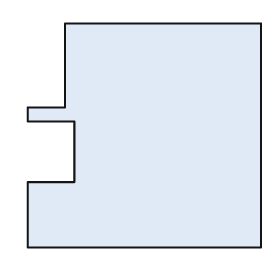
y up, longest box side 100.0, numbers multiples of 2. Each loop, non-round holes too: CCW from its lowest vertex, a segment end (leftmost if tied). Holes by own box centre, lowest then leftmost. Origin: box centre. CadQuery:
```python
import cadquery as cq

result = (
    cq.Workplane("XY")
    .moveTo(-50.0, -48.0)
    .lineTo(50.0, -48.0)
    .lineTo(50.0, 48.0)
    .lineTo(-34.0, 48.0)
    .lineTo(-34.0, 12.0)
    .lineTo(-50.0, 12.0)
    .lineTo(-50.0, 6.0)
    .lineTo(-30.0, 6.0)
    .lineTo(-30.0, -20.0)
    .lineTo(-50.0, -20.0)
    .close()
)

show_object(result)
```